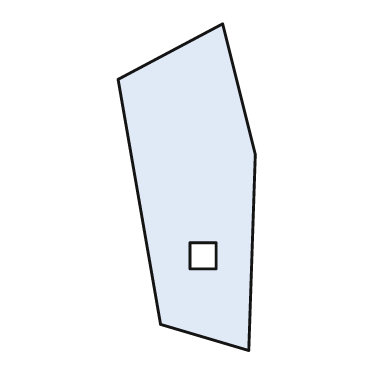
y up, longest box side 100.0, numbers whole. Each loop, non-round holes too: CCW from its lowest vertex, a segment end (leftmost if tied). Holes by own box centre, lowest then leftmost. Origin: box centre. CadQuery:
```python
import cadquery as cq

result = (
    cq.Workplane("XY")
    .moveTo(19.0, -50.0)
    .lineTo(21.0, 10.0)
    .lineTo(11.0, 50.0)
    .lineTo(-21.0, 33.0)
    .lineTo(-8.0, -42.0)
    .close()
    .moveTo(1.0, -25.0)
    .lineTo(9.0, -25.0)
    .lineTo(9.0, -17.0)
    .lineTo(1.0, -17.0)
    .close()
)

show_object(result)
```